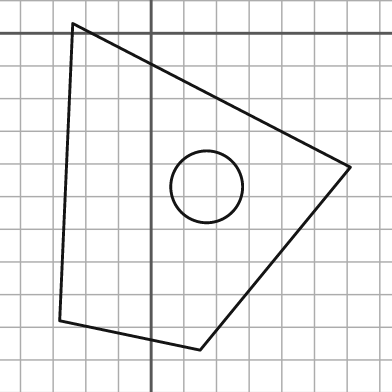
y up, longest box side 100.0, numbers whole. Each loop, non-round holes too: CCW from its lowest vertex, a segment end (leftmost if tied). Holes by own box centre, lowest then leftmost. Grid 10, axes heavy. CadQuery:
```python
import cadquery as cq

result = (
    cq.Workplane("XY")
    .moveTo(15.0, -97.0)
    .lineTo(61.0, -41.0)
    .lineTo(-24.0, 3.0)
    .lineTo(-28.0, -88.0)
    .close()
    .moveTo(17.0, -47.0)
    .circle(11.0)
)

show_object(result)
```